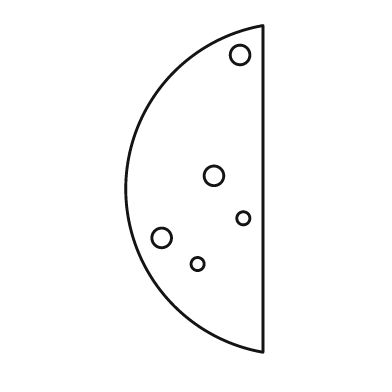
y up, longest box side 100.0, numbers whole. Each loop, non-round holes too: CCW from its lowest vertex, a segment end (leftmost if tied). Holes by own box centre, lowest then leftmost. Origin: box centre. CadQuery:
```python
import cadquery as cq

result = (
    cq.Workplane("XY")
    .moveTo(21.0, -50.0)
    .lineTo(21.0, 50.0)
    .threePointArc((-21.0, 0.0), (21.0, -50.0))
    .close()
    .moveTo(1.0, -23.0)
    .circle(2.0)
    .moveTo(-10.0, -15.0)
    .circle(3.0)
    .moveTo(15.0, -9.0)
    .circle(2.0)
    .moveTo(6.0, 4.0)
    .circle(3.0)
    .moveTo(14.0, 41.0)
    .circle(3.0)
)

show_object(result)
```